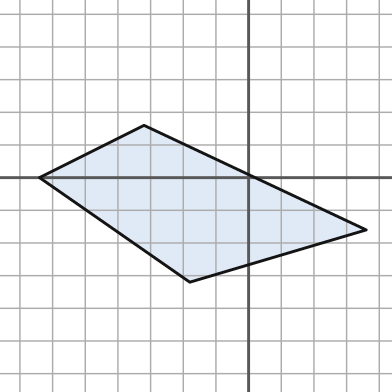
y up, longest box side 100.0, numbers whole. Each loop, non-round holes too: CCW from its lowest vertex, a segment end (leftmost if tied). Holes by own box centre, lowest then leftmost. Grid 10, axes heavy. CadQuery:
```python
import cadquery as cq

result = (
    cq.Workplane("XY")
    .moveTo(-18.0, -32.0)
    .lineTo(36.0, -16.0)
    .lineTo(-32.0, 16.0)
    .lineTo(-64.0, 0.0)
    .close()
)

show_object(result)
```